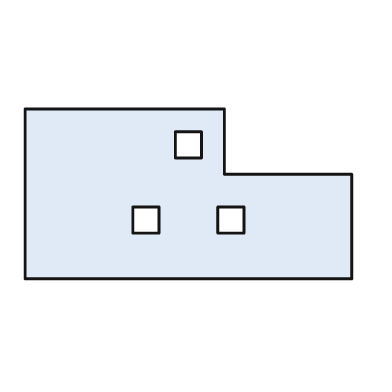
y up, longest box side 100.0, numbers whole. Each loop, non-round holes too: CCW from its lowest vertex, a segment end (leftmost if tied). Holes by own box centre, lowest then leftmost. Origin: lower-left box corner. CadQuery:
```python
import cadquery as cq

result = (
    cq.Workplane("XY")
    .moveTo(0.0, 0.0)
    .lineTo(100.0, 0.0)
    .lineTo(100.0, 32.0)
    .lineTo(61.0, 32.0)
    .lineTo(61.0, 52.0)
    .lineTo(0.0, 52.0)
    .close()
    .moveTo(33.0, 14.0)
    .lineTo(41.0, 14.0)
    .lineTo(41.0, 22.0)
    .lineTo(33.0, 22.0)
    .close()
    .moveTo(59.0, 14.0)
    .lineTo(67.0, 14.0)
    .lineTo(67.0, 22.0)
    .lineTo(59.0, 22.0)
    .close()
    .moveTo(46.0, 37.0)
    .lineTo(54.0, 37.0)
    .lineTo(54.0, 45.0)
    .lineTo(46.0, 45.0)
    .close()
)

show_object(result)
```